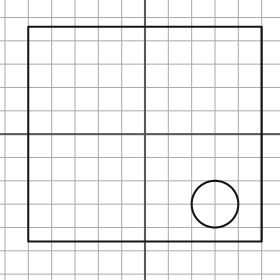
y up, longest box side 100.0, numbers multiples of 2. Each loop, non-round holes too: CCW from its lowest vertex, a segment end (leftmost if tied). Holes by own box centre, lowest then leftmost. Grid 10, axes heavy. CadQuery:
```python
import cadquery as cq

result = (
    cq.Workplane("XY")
    .moveTo(-50.0, -46.0)
    .lineTo(50.0, -46.0)
    .lineTo(50.0, 46.0)
    .lineTo(-50.0, 46.0)
    .close()
    .moveTo(30.0, -30.0)
    .circle(10.0)
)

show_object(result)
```